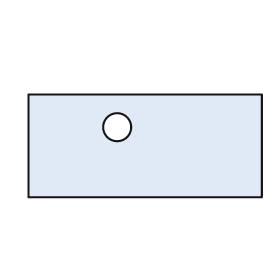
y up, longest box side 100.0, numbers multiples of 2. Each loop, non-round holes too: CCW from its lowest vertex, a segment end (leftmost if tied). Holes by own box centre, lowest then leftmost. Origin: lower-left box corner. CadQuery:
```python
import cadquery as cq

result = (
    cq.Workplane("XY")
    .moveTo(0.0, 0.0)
    .lineTo(100.0, 0.0)
    .lineTo(100.0, 44.0)
    .lineTo(0.0, 44.0)
    .close()
    .moveTo(38.0, 30.0)
    .circle(6.0)
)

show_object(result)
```